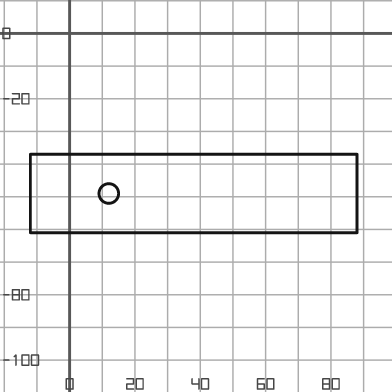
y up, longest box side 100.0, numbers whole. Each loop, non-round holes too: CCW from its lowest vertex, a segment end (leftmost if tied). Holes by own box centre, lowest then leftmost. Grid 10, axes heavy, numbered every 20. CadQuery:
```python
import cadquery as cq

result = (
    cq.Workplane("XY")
    .moveTo(-12.0, -61.0)
    .lineTo(88.0, -61.0)
    .lineTo(88.0, -37.0)
    .lineTo(-12.0, -37.0)
    .close()
    .moveTo(12.0, -49.0)
    .circle(3.0)
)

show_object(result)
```